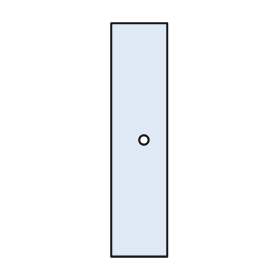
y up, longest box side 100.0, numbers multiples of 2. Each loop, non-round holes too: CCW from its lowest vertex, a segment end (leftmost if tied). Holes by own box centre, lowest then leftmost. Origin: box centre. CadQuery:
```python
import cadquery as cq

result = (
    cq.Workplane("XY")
    .moveTo(-12.0, -50.0)
    .lineTo(12.0, -50.0)
    .lineTo(12.0, 50.0)
    .lineTo(-12.0, 50.0)
    .close()
    .moveTo(2.0, 0.0)
    .circle(2.0)
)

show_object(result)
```